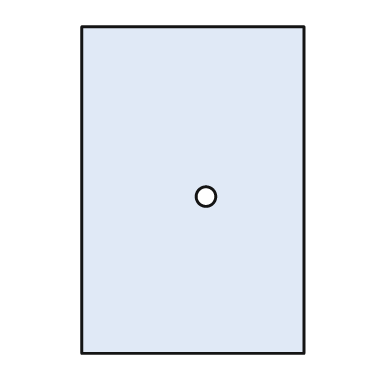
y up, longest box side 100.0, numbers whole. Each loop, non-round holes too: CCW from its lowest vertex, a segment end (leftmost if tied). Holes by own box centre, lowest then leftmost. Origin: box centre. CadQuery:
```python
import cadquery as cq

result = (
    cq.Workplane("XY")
    .moveTo(-34.0, -50.0)
    .lineTo(34.0, -50.0)
    .lineTo(34.0, 50.0)
    .lineTo(-34.0, 50.0)
    .close()
    .moveTo(4.0, -2.0)
    .circle(3.0)
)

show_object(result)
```